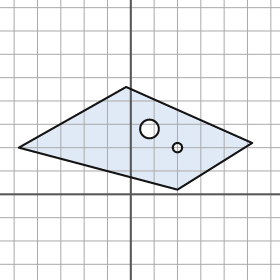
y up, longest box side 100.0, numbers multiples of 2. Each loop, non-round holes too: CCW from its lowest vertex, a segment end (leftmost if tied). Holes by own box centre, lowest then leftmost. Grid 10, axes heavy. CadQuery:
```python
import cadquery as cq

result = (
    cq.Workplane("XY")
    .moveTo(20.0, 2.0)
    .lineTo(52.0, 22.0)
    .lineTo(-2.0, 46.0)
    .lineTo(-48.0, 20.0)
    .close()
    .moveTo(20.0, 20.0)
    .circle(2.0)
    .moveTo(8.0, 28.0)
    .circle(4.0)
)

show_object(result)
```